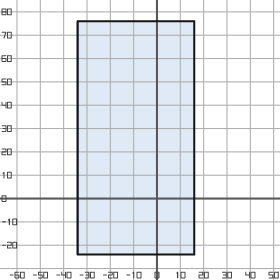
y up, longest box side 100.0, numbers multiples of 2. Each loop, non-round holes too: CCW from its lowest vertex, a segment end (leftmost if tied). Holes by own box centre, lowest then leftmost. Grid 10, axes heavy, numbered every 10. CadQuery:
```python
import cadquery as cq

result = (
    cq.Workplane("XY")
    .moveTo(-34.0, -24.0)
    .lineTo(16.0, -24.0)
    .lineTo(16.0, 76.0)
    .lineTo(-34.0, 76.0)
    .close()
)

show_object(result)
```